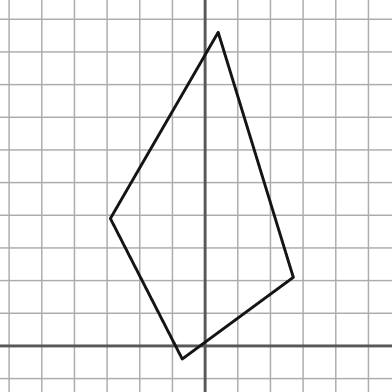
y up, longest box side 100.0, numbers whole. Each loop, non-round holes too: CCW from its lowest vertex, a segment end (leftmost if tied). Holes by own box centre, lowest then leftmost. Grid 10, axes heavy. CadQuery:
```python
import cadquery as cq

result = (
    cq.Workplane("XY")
    .moveTo(-7.0, -4.0)
    .lineTo(27.0, 21.0)
    .lineTo(4.0, 96.0)
    .lineTo(-29.0, 39.0)
    .close()
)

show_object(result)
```